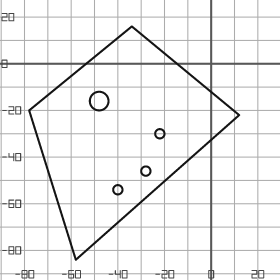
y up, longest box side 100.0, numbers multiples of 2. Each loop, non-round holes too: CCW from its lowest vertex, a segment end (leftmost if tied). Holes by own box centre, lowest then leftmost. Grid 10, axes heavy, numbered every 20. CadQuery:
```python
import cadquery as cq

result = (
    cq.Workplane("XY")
    .moveTo(-58.0, -84.0)
    .lineTo(12.0, -22.0)
    .lineTo(-34.0, 16.0)
    .lineTo(-78.0, -20.0)
    .close()
    .moveTo(-40.0, -54.0)
    .circle(2.0)
    .moveTo(-28.0, -46.0)
    .circle(2.0)
    .moveTo(-22.0, -30.0)
    .circle(2.0)
    .moveTo(-48.0, -16.0)
    .circle(4.0)
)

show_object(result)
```